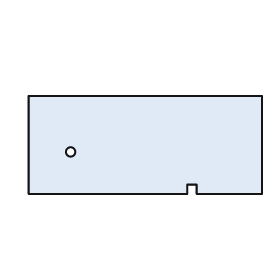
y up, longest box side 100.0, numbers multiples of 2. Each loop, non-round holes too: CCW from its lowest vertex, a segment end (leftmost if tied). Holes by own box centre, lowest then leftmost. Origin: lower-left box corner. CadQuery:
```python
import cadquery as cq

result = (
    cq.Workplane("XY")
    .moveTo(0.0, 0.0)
    .lineTo(68.0, 0.0)
    .lineTo(68.0, 4.0)
    .lineTo(72.0, 4.0)
    .lineTo(72.0, 0.0)
    .lineTo(100.0, 0.0)
    .lineTo(100.0, 42.0)
    .lineTo(0.0, 42.0)
    .close()
    .moveTo(18.0, 18.0)
    .circle(2.0)
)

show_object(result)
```